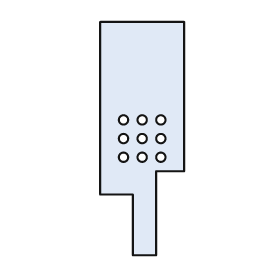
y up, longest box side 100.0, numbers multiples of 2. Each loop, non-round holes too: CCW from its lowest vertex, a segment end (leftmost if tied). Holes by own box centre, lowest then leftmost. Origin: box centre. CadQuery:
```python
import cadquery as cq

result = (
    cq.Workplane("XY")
    .moveTo(-4.0, -50.0)
    .lineTo(6.0, -50.0)
    .lineTo(6.0, -14.0)
    .lineTo(18.0, -14.0)
    .lineTo(18.0, 50.0)
    .lineTo(-18.0, 50.0)
    .lineTo(-18.0, -24.0)
    .lineTo(-4.0, -24.0)
    .close()
    .moveTo(-8.0, -8.0)
    .circle(2.0)
    .moveTo(0.0, -8.0)
    .circle(2.0)
    .moveTo(8.0, -8.0)
    .circle(2.0)
    .moveTo(-8.0, 0.0)
    .circle(2.0)
    .moveTo(0.0, 0.0)
    .circle(2.0)
    .moveTo(8.0, 0.0)
    .circle(2.0)
    .moveTo(-8.0, 8.0)
    .circle(2.0)
    .moveTo(0.0, 8.0)
    .circle(2.0)
    .moveTo(8.0, 8.0)
    .circle(2.0)
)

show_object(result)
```